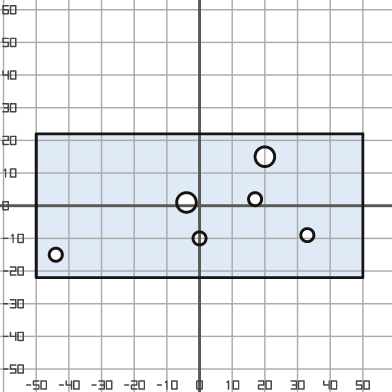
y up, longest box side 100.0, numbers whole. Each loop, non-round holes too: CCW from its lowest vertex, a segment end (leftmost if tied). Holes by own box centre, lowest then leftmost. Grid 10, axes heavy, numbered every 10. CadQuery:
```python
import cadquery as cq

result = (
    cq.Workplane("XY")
    .moveTo(-50.0, -22.0)
    .lineTo(50.0, -22.0)
    .lineTo(50.0, 22.0)
    .lineTo(-50.0, 22.0)
    .close()
    .moveTo(-44.0, -15.0)
    .circle(2.0)
    .moveTo(0.0, -10.0)
    .circle(2.0)
    .moveTo(33.0, -9.0)
    .circle(2.0)
    .moveTo(-4.0, 1.0)
    .circle(3.0)
    .moveTo(17.0, 2.0)
    .circle(2.0)
    .moveTo(20.0, 15.0)
    .circle(3.0)
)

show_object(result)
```